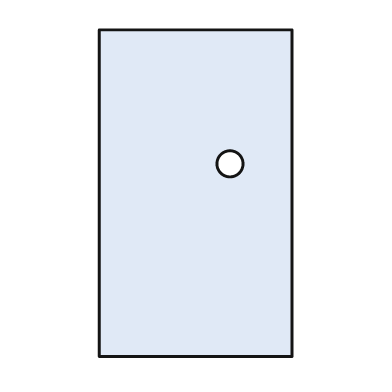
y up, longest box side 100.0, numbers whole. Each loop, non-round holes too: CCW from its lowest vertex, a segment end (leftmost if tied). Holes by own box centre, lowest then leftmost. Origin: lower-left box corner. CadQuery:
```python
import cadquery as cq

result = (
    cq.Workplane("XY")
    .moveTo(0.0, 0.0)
    .lineTo(59.0, 0.0)
    .lineTo(59.0, 100.0)
    .lineTo(0.0, 100.0)
    .close()
    .moveTo(40.0, 59.0)
    .circle(4.0)
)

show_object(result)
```